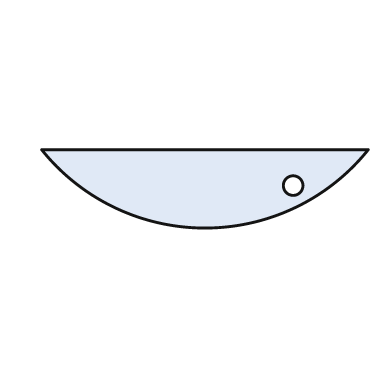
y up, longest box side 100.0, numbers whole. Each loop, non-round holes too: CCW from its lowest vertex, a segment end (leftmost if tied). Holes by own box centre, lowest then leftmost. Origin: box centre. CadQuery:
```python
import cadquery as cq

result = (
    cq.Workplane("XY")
    .moveTo(-50.0, 12.0)
    .threePointArc((0.0, -12.0), (50.0, 12.0))
    .close()
    .moveTo(27.0, 1.0)
    .circle(3.0)
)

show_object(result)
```